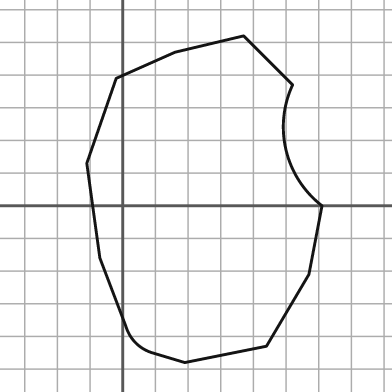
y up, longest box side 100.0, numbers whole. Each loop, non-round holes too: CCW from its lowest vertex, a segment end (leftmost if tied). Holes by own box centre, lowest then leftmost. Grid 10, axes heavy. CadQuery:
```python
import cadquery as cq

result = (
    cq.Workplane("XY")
    .moveTo(19.0, -48.0)
    .lineTo(44.0, -43.0)
    .lineTo(57.0, -21.0)
    .lineTo(61.0, 0.0)
    .threePointArc((50.0, 17.0), (52.0, 37.0))
    .lineTo(37.0, 52.0)
    .lineTo(16.0, 47.0)
    .lineTo(-2.0, 39.0)
    .lineTo(-11.0, 13.0)
    .lineTo(-7.0, -16.0)
    .lineTo(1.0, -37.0)
    .threePointArc((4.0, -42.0), (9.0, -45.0))
    .close()
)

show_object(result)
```